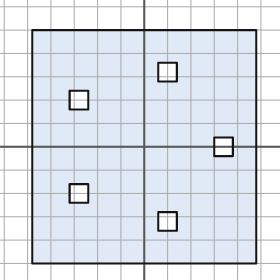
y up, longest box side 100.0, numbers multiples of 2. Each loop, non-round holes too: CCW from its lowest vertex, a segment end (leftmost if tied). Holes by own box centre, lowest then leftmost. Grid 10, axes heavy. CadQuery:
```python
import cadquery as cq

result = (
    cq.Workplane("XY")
    .moveTo(-48.0, -50.0)
    .lineTo(48.0, -50.0)
    .lineTo(48.0, 50.0)
    .lineTo(-48.0, 50.0)
    .close()
    .moveTo(6.0, -36.0)
    .lineTo(14.0, -36.0)
    .lineTo(14.0, -28.0)
    .lineTo(6.0, -28.0)
    .close()
    .moveTo(-32.0, -24.0)
    .lineTo(-24.0, -24.0)
    .lineTo(-24.0, -16.0)
    .lineTo(-32.0, -16.0)
    .close()
    .moveTo(30.0, -4.0)
    .lineTo(38.0, -4.0)
    .lineTo(38.0, 4.0)
    .lineTo(30.0, 4.0)
    .close()
    .moveTo(-32.0, 16.0)
    .lineTo(-24.0, 16.0)
    .lineTo(-24.0, 24.0)
    .lineTo(-32.0, 24.0)
    .close()
    .moveTo(6.0, 28.0)
    .lineTo(14.0, 28.0)
    .lineTo(14.0, 36.0)
    .lineTo(6.0, 36.0)
    .close()
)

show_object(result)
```